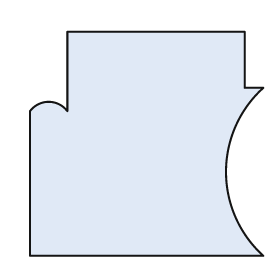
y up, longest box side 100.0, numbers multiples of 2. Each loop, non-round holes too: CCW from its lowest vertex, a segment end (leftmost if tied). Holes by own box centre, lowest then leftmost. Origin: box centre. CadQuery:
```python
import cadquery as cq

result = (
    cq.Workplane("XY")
    .moveTo(-50.0, -48.0)
    .lineTo(50.0, -48.0)
    .threePointArc((34.0, -12.0), (50.0, 24.0))
    .lineTo(42.0, 24.0)
    .lineTo(42.0, 48.0)
    .lineTo(-34.0, 48.0)
    .lineTo(-34.0, 14.0)
    .threePointArc((-42.0, 18.0), (-50.0, 14.0))
    .close()
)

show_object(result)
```